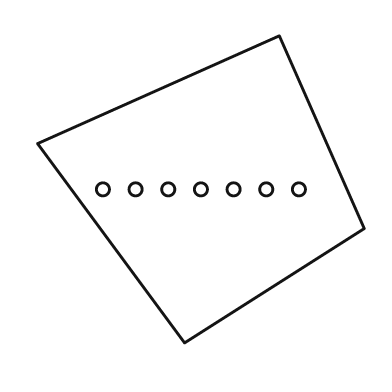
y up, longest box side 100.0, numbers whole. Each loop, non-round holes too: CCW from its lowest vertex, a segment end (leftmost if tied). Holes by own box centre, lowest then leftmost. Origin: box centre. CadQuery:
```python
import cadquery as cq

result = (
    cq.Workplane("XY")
    .moveTo(-5.0, -47.0)
    .lineTo(50.0, -12.0)
    .lineTo(24.0, 47.0)
    .lineTo(-50.0, 14.0)
    .close()
    .moveTo(-30.0, 0.0)
    .circle(2.0)
    .moveTo(-20.0, 0.0)
    .circle(2.0)
    .moveTo(-10.0, 0.0)
    .circle(2.0)
    .moveTo(0.0, 0.0)
    .circle(2.0)
    .moveTo(10.0, 0.0)
    .circle(2.0)
    .moveTo(20.0, 0.0)
    .circle(2.0)
    .moveTo(30.0, 0.0)
    .circle(2.0)
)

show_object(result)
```